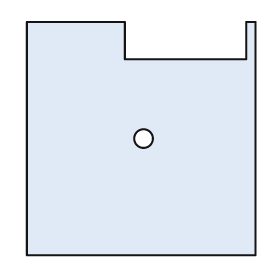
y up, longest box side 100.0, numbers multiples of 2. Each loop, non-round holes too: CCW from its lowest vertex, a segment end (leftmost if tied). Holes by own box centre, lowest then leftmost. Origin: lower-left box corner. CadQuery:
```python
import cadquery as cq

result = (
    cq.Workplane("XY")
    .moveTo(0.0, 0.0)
    .lineTo(98.0, 0.0)
    .lineTo(98.0, 100.0)
    .lineTo(94.0, 100.0)
    .lineTo(94.0, 84.0)
    .lineTo(42.0, 84.0)
    .lineTo(42.0, 100.0)
    .lineTo(0.0, 100.0)
    .close()
    .moveTo(50.0, 50.0)
    .circle(4.0)
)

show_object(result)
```